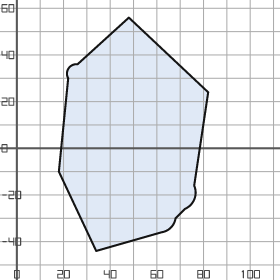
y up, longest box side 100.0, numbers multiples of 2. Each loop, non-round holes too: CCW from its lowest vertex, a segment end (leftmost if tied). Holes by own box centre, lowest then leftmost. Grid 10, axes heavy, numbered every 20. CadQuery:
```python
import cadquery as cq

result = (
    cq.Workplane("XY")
    .moveTo(34.0, -44.0)
    .lineTo(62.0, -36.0)
    .threePointArc((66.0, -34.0), (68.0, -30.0))
    .lineTo(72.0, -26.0)
    .threePointArc((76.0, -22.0), (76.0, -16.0))
    .lineTo(82.0, 24.0)
    .lineTo(48.0, 56.0)
    .lineTo(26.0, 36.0)
    .threePointArc((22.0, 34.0), (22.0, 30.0))
    .lineTo(18.0, -10.0)
    .close()
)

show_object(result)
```